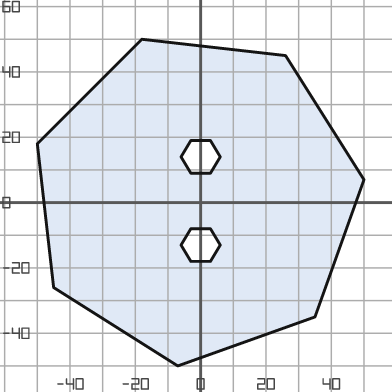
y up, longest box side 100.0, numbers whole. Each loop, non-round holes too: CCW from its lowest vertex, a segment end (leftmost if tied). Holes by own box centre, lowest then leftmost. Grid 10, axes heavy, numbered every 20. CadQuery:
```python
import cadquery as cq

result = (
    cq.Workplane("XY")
    .moveTo(-7.0, -50.0)
    .lineTo(35.0, -35.0)
    .lineTo(50.0, 7.0)
    .lineTo(26.0, 45.0)
    .lineTo(-18.0, 50.0)
    .lineTo(-50.0, 18.0)
    .lineTo(-45.0, -26.0)
    .close()
    .moveTo(-3.0, -18.0)
    .lineTo(3.0, -18.0)
    .lineTo(6.0, -13.0)
    .lineTo(3.0, -8.0)
    .lineTo(-3.0, -8.0)
    .lineTo(-6.0, -13.0)
    .close()
    .moveTo(-3.0, 9.0)
    .lineTo(3.0, 9.0)
    .lineTo(6.0, 14.0)
    .lineTo(3.0, 19.0)
    .lineTo(-3.0, 19.0)
    .lineTo(-6.0, 14.0)
    .close()
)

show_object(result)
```